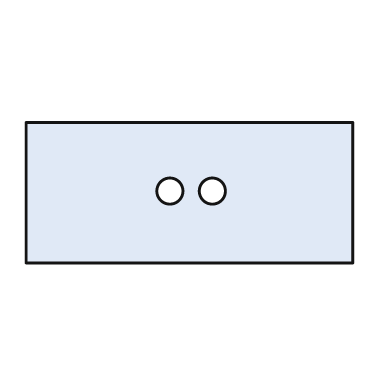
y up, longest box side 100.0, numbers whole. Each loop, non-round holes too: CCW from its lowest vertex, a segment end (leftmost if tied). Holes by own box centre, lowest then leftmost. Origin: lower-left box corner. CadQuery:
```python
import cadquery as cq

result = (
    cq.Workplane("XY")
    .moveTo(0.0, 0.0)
    .lineTo(100.0, 0.0)
    .lineTo(100.0, 43.0)
    .lineTo(0.0, 43.0)
    .close()
    .moveTo(44.0, 22.0)
    .circle(4.0)
    .moveTo(57.0, 22.0)
    .circle(4.0)
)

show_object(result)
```